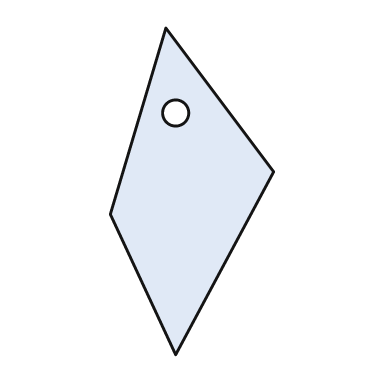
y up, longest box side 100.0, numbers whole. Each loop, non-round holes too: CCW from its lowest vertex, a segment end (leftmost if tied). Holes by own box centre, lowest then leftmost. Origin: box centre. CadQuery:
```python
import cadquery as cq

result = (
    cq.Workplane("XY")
    .moveTo(-5.0, -50.0)
    .lineTo(25.0, 6.0)
    .lineTo(-8.0, 50.0)
    .lineTo(-25.0, -7.0)
    .close()
    .moveTo(-5.0, 24.0)
    .circle(4.0)
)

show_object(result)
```